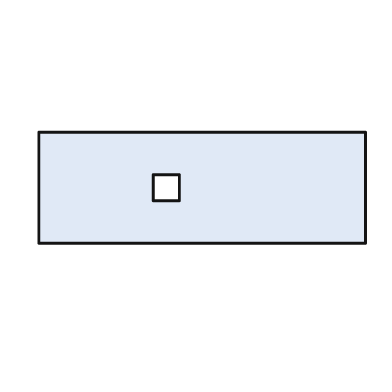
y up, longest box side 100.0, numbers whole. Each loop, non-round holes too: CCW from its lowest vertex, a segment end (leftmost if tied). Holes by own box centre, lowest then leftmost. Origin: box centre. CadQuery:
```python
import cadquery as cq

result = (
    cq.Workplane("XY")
    .moveTo(-50.0, -17.0)
    .lineTo(50.0, -17.0)
    .lineTo(50.0, 17.0)
    .lineTo(-50.0, 17.0)
    .close()
    .moveTo(-15.0, -4.0)
    .lineTo(-7.0, -4.0)
    .lineTo(-7.0, 4.0)
    .lineTo(-15.0, 4.0)
    .close()
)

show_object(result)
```